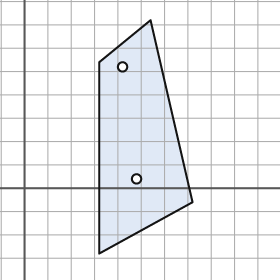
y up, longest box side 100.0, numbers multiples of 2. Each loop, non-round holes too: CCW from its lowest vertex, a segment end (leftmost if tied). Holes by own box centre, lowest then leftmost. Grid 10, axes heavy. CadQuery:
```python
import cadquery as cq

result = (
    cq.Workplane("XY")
    .moveTo(32.0, -28.0)
    .lineTo(72.0, -6.0)
    .lineTo(54.0, 72.0)
    .lineTo(32.0, 54.0)
    .close()
    .moveTo(48.0, 4.0)
    .circle(2.0)
    .moveTo(42.0, 52.0)
    .circle(2.0)
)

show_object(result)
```